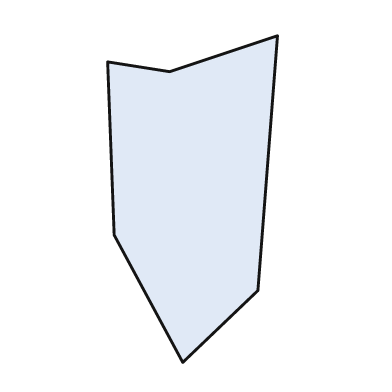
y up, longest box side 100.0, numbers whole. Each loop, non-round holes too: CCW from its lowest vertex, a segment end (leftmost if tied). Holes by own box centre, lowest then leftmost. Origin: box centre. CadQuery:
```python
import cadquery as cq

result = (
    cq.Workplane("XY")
    .moveTo(-3.0, -50.0)
    .lineTo(20.0, -28.0)
    .lineTo(26.0, 50.0)
    .lineTo(-7.0, 39.0)
    .lineTo(-26.0, 42.0)
    .lineTo(-24.0, -11.0)
    .close()
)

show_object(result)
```